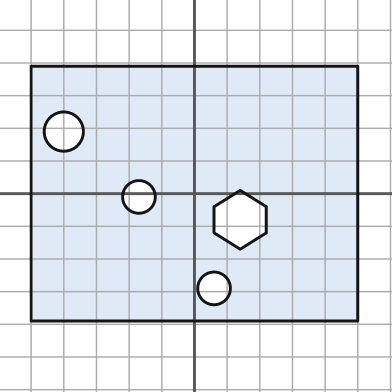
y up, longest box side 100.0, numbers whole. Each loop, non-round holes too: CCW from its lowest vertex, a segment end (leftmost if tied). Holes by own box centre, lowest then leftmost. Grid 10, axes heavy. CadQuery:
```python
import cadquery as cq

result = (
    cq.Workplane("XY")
    .moveTo(-50.0, -39.0)
    .lineTo(50.0, -39.0)
    .lineTo(50.0, 39.0)
    .lineTo(-50.0, 39.0)
    .close()
    .moveTo(6.0, -29.0)
    .circle(5.0)
    .moveTo(14.0, -17.0)
    .lineTo(22.0, -12.0)
    .lineTo(22.0, -4.0)
    .lineTo(14.0, 1.0)
    .lineTo(6.0, -4.0)
    .lineTo(6.0, -12.0)
    .close()
    .moveTo(-17.0, -1.0)
    .circle(5.0)
    .moveTo(-40.0, 19.0)
    .circle(6.0)
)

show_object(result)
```